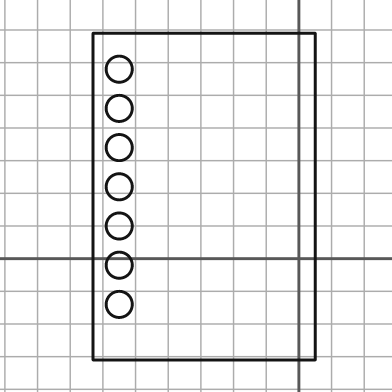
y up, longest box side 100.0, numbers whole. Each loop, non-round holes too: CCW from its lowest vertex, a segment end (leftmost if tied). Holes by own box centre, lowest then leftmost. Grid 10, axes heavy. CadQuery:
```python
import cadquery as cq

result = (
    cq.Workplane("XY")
    .moveTo(-63.0, -31.0)
    .lineTo(5.0, -31.0)
    .lineTo(5.0, 69.0)
    .lineTo(-63.0, 69.0)
    .close()
    .moveTo(-55.0, -14.0)
    .circle(4.0)
    .moveTo(-55.0, -2.0)
    .circle(4.0)
    .moveTo(-55.0, 10.0)
    .circle(4.0)
    .moveTo(-55.0, 22.0)
    .circle(4.0)
    .moveTo(-55.0, 34.0)
    .circle(4.0)
    .moveTo(-55.0, 46.0)
    .circle(4.0)
    .moveTo(-55.0, 58.0)
    .circle(4.0)
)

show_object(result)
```